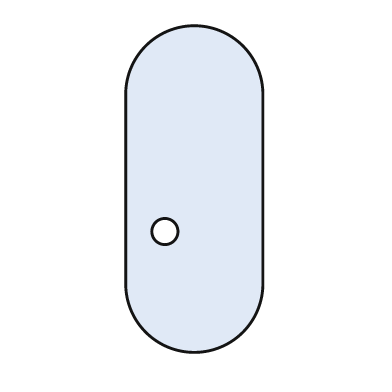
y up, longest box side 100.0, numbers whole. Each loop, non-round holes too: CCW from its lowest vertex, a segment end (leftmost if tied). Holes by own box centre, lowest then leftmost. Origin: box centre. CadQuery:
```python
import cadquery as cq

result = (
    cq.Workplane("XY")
    .moveTo(-21.0, -29.0)
    .threePointArc((0.0, -50.0), (21.0, -29.0))
    .lineTo(21.0, 29.0)
    .threePointArc((0.0, 50.0), (-21.0, 29.0))
    .close()
    .moveTo(-9.0, -13.0)
    .circle(4.0)
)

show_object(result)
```